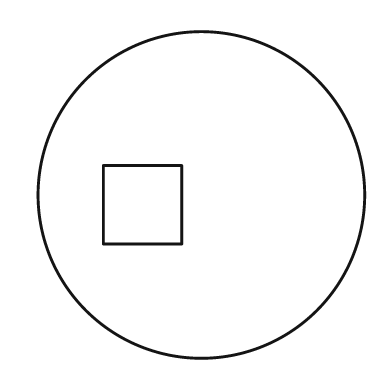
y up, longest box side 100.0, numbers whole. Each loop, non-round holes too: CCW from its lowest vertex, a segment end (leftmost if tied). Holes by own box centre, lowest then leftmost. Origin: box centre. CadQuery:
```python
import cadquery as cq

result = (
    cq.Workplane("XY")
    .moveTo(0.0, 0.0)
    .circle(50.0)
    .moveTo(-30.0, -15.0)
    .lineTo(-6.0, -15.0)
    .lineTo(-6.0, 9.0)
    .lineTo(-30.0, 9.0)
    .close()
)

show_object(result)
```